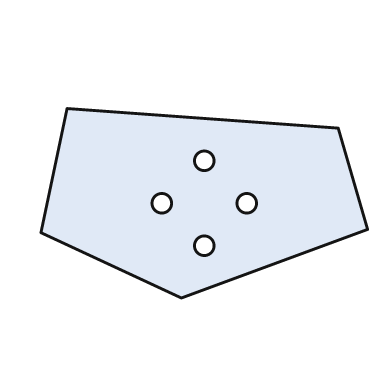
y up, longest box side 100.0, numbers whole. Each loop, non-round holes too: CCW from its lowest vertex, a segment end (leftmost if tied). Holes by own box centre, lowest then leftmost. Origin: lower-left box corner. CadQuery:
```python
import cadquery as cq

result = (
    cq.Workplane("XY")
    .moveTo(43.0, 0.0)
    .lineTo(100.0, 21.0)
    .lineTo(91.0, 52.0)
    .lineTo(8.0, 58.0)
    .lineTo(0.0, 20.0)
    .close()
    .moveTo(50.0, 16.0)
    .circle(3.0)
    .moveTo(37.0, 29.0)
    .circle(3.0)
    .moveTo(63.0, 29.0)
    .circle(3.0)
    .moveTo(50.0, 42.0)
    .circle(3.0)
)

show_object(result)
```